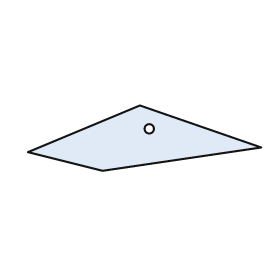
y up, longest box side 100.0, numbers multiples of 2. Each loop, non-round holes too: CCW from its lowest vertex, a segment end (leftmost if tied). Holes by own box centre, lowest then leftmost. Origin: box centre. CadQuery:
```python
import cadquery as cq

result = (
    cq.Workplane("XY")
    .moveTo(-18.0, -14.0)
    .lineTo(50.0, -4.0)
    .lineTo(-2.0, 14.0)
    .lineTo(-50.0, -6.0)
    .close()
    .moveTo(2.0, 4.0)
    .circle(2.0)
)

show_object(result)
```